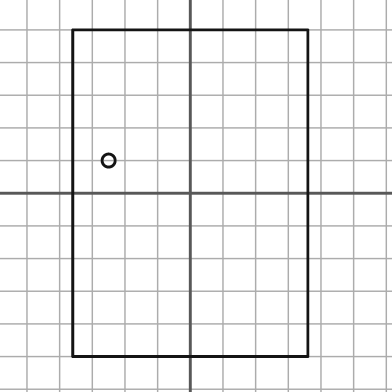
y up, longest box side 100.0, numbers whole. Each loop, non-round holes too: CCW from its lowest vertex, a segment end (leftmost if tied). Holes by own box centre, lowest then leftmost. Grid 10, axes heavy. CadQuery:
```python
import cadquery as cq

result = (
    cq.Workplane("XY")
    .moveTo(-36.0, -50.0)
    .lineTo(36.0, -50.0)
    .lineTo(36.0, 50.0)
    .lineTo(-36.0, 50.0)
    .close()
    .moveTo(-25.0, 10.0)
    .circle(2.0)
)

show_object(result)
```